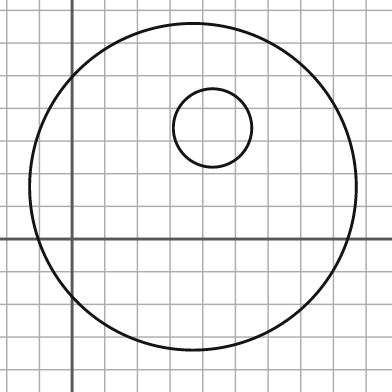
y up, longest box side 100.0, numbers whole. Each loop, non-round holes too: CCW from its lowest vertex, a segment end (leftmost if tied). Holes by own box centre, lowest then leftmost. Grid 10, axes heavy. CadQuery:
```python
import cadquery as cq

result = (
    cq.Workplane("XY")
    .moveTo(37.0, 16.0)
    .circle(50.0)
    .moveTo(43.0, 34.0)
    .circle(12.0)
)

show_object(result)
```